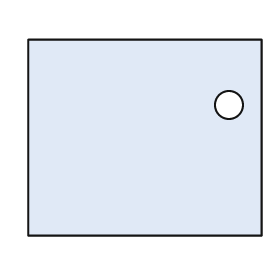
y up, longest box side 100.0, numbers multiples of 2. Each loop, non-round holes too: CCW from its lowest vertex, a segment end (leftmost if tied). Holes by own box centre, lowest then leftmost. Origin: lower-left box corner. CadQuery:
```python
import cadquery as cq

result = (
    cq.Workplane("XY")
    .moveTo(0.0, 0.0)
    .lineTo(100.0, 0.0)
    .lineTo(100.0, 84.0)
    .lineTo(0.0, 84.0)
    .close()
    .moveTo(86.0, 56.0)
    .circle(6.0)
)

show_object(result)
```